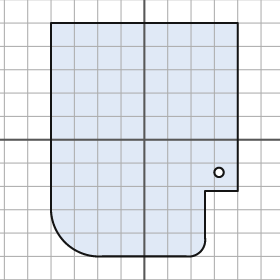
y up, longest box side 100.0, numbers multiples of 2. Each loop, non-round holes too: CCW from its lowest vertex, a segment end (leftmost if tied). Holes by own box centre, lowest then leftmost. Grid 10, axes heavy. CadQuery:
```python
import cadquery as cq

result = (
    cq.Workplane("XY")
    .moveTo(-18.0, -50.0)
    .lineTo(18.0, -50.0)
    .threePointArc((24.0, -48.0), (26.0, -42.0))
    .lineTo(26.0, -22.0)
    .lineTo(40.0, -22.0)
    .lineTo(40.0, 50.0)
    .lineTo(-40.0, 50.0)
    .lineTo(-40.0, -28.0)
    .threePointArc((-34.0, -44.0), (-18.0, -50.0))
    .close()
    .moveTo(32.0, -14.0)
    .circle(2.0)
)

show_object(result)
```